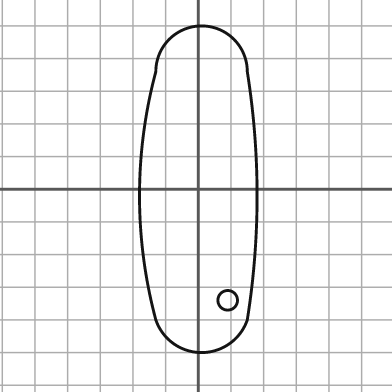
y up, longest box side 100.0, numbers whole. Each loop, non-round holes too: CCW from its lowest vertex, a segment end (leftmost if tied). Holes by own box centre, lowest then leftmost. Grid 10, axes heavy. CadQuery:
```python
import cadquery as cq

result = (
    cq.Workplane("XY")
    .moveTo(-13.0, -40.0)
    .threePointArc((1.0, -50.0), (15.0, -40.0))
    .threePointArc((18.0, -2.0), (15.0, 36.0))
    .threePointArc((1.0, 50.0), (-13.0, 36.0))
    .threePointArc((-18.0, -2.0), (-13.0, -40.0))
    .close()
    .moveTo(9.0, -34.0)
    .circle(3.0)
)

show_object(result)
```